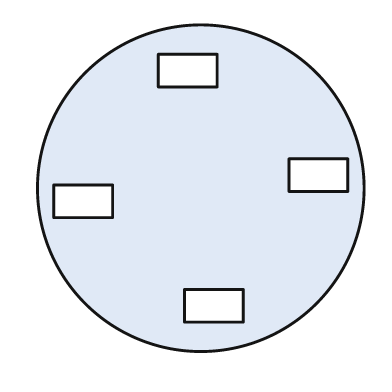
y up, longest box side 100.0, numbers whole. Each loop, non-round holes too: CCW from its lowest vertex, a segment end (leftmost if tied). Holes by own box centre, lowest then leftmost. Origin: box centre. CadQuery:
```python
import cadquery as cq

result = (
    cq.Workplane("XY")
    .moveTo(0.0, 0.0)
    .circle(50.0)
    .moveTo(-5.0, -41.0)
    .lineTo(13.0, -41.0)
    .lineTo(13.0, -31.0)
    .lineTo(-5.0, -31.0)
    .close()
    .moveTo(-45.0, -9.0)
    .lineTo(-27.0, -9.0)
    .lineTo(-27.0, 1.0)
    .lineTo(-45.0, 1.0)
    .close()
    .moveTo(27.0, -1.0)
    .lineTo(45.0, -1.0)
    .lineTo(45.0, 9.0)
    .lineTo(27.0, 9.0)
    .close()
    .moveTo(-13.0, 31.0)
    .lineTo(5.0, 31.0)
    .lineTo(5.0, 41.0)
    .lineTo(-13.0, 41.0)
    .close()
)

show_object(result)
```